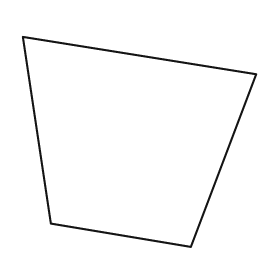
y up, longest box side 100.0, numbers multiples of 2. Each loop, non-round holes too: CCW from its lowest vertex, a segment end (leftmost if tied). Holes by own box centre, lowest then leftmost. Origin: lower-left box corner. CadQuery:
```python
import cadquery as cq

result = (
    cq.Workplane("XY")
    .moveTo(72.0, 0.0)
    .lineTo(100.0, 74.0)
    .lineTo(0.0, 90.0)
    .lineTo(12.0, 10.0)
    .close()
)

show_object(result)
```